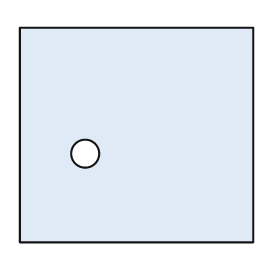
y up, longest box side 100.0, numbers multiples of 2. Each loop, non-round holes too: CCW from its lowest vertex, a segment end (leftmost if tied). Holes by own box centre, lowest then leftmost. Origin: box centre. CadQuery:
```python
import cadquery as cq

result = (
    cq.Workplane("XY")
    .moveTo(-50.0, -46.0)
    .lineTo(50.0, -46.0)
    .lineTo(50.0, 46.0)
    .lineTo(-50.0, 46.0)
    .close()
    .moveTo(-22.0, -8.0)
    .circle(6.0)
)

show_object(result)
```